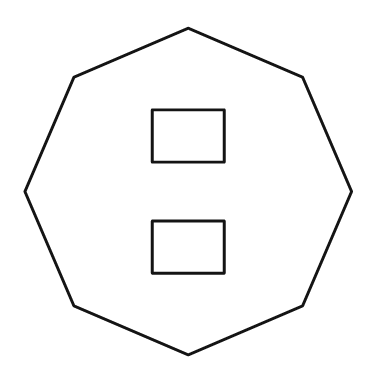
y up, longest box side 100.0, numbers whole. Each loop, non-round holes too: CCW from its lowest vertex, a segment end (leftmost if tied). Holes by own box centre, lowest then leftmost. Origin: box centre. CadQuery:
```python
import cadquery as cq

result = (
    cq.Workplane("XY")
    .moveTo(0.0, -50.0)
    .lineTo(35.0, -35.0)
    .lineTo(50.0, 0.0)
    .lineTo(35.0, 35.0)
    .lineTo(0.0, 50.0)
    .lineTo(-35.0, 35.0)
    .lineTo(-50.0, 0.0)
    .lineTo(-35.0, -35.0)
    .close()
    .moveTo(-11.0, -25.0)
    .lineTo(11.0, -25.0)
    .lineTo(11.0, -9.0)
    .lineTo(-11.0, -9.0)
    .close()
    .moveTo(-11.0, 9.0)
    .lineTo(11.0, 9.0)
    .lineTo(11.0, 25.0)
    .lineTo(-11.0, 25.0)
    .close()
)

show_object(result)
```